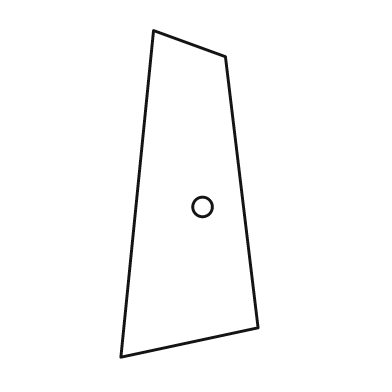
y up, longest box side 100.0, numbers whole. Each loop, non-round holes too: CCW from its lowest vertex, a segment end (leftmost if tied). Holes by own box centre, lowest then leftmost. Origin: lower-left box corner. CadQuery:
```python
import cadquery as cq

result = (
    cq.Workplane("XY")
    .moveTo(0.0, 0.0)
    .lineTo(42.0, 9.0)
    .lineTo(32.0, 92.0)
    .lineTo(10.0, 100.0)
    .close()
    .moveTo(25.0, 46.0)
    .circle(3.0)
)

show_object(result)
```